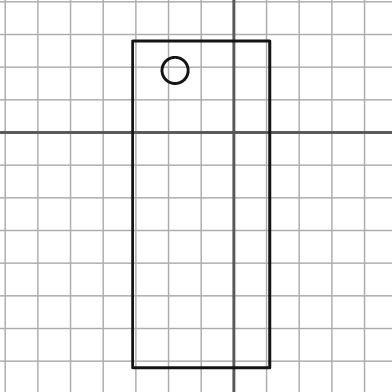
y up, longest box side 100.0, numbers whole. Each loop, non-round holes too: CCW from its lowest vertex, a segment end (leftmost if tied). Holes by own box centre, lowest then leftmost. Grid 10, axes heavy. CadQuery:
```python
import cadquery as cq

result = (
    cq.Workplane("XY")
    .moveTo(-31.0, -72.0)
    .lineTo(11.0, -72.0)
    .lineTo(11.0, 28.0)
    .lineTo(-31.0, 28.0)
    .close()
    .moveTo(-18.0, 19.0)
    .circle(4.0)
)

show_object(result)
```